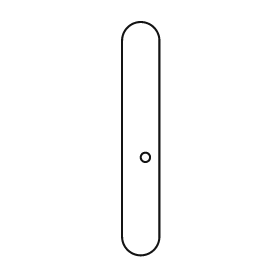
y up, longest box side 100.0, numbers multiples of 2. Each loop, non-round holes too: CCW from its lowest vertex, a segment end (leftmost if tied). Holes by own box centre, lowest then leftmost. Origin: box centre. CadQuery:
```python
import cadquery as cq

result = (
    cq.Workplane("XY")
    .moveTo(-8.0, -42.0)
    .threePointArc((0.0, -50.0), (8.0, -42.0))
    .lineTo(8.0, 42.0)
    .threePointArc((0.0, 50.0), (-8.0, 42.0))
    .close()
    .moveTo(2.0, -8.0)
    .circle(2.0)
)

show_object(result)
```